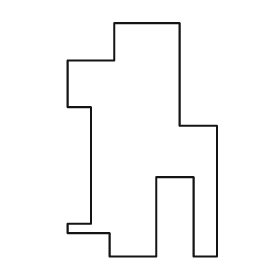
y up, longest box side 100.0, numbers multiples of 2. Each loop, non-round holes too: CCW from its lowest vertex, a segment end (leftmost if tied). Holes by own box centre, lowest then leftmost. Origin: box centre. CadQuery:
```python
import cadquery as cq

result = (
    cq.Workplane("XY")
    .moveTo(-14.0, -50.0)
    .lineTo(6.0, -50.0)
    .lineTo(6.0, -16.0)
    .lineTo(22.0, -16.0)
    .lineTo(22.0, -50.0)
    .lineTo(32.0, -50.0)
    .lineTo(32.0, 6.0)
    .lineTo(16.0, 6.0)
    .lineTo(16.0, 50.0)
    .lineTo(-12.0, 50.0)
    .lineTo(-12.0, 34.0)
    .lineTo(-32.0, 34.0)
    .lineTo(-32.0, 14.0)
    .lineTo(-22.0, 14.0)
    .lineTo(-22.0, -36.0)
    .lineTo(-32.0, -36.0)
    .lineTo(-32.0, -40.0)
    .lineTo(-14.0, -40.0)
    .close()
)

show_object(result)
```